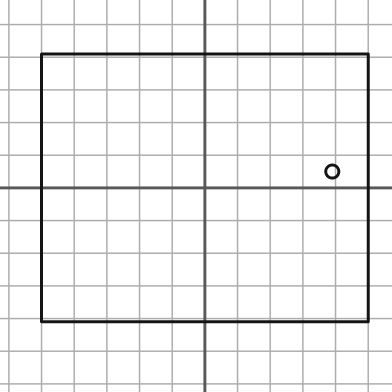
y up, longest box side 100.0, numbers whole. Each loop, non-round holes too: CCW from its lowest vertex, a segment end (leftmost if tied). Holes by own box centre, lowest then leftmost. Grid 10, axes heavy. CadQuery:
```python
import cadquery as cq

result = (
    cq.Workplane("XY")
    .moveTo(-50.0, -41.0)
    .lineTo(50.0, -41.0)
    .lineTo(50.0, 41.0)
    .lineTo(-50.0, 41.0)
    .close()
    .moveTo(39.0, 5.0)
    .circle(2.0)
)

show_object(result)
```